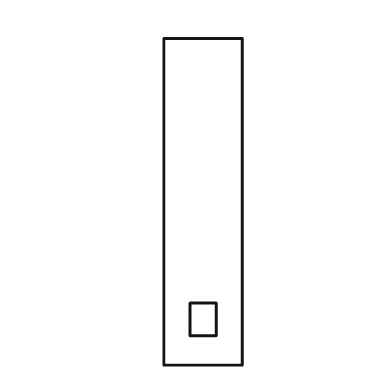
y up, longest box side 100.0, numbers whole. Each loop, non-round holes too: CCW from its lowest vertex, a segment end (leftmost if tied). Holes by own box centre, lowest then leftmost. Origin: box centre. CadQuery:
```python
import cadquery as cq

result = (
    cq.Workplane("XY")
    .moveTo(-12.0, -50.0)
    .lineTo(12.0, -50.0)
    .lineTo(12.0, 50.0)
    .lineTo(-12.0, 50.0)
    .close()
    .moveTo(-4.0, -41.0)
    .lineTo(4.0, -41.0)
    .lineTo(4.0, -31.0)
    .lineTo(-4.0, -31.0)
    .close()
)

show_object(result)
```